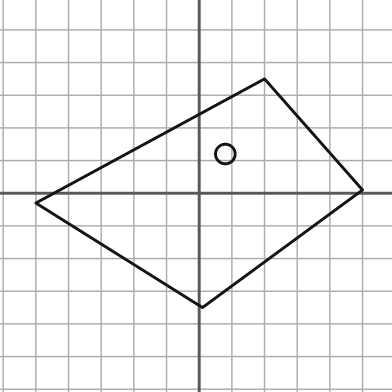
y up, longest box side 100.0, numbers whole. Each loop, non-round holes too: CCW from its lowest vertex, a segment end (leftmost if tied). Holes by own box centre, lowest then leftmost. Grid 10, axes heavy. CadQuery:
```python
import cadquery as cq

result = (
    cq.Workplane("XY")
    .moveTo(1.0, -35.0)
    .lineTo(50.0, 1.0)
    .lineTo(20.0, 35.0)
    .lineTo(-50.0, -3.0)
    .close()
    .moveTo(8.0, 12.0)
    .circle(3.0)
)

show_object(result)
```